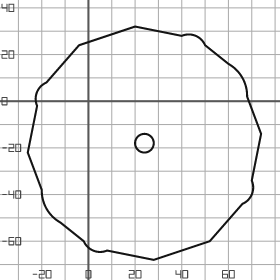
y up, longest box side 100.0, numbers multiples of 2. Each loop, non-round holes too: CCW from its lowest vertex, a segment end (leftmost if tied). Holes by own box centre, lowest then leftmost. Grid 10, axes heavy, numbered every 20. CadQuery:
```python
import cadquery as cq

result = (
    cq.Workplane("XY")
    .moveTo(28.0, -68.0)
    .lineTo(52.0, -60.0)
    .lineTo(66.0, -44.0)
    .threePointArc((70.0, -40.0), (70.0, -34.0))
    .lineTo(74.0, -14.0)
    .lineTo(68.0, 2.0)
    .threePointArc((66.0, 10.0), (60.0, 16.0))
    .lineTo(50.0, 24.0)
    .threePointArc((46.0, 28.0), (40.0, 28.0))
    .lineTo(20.0, 32.0)
    .lineTo(-4.0, 24.0)
    .lineTo(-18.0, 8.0)
    .threePointArc((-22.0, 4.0), (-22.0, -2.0))
    .lineTo(-26.0, -22.0)
    .lineTo(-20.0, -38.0)
    .threePointArc((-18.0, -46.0), (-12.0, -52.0))
    .lineTo(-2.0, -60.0)
    .threePointArc((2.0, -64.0), (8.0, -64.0))
    .close()
    .moveTo(24.0, -18.0)
    .circle(4.0)
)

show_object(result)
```